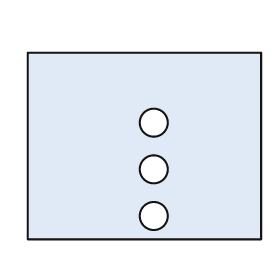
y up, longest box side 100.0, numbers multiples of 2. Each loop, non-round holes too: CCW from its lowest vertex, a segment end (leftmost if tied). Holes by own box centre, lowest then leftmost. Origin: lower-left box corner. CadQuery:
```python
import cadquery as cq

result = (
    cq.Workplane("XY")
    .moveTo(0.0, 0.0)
    .lineTo(100.0, 0.0)
    .lineTo(100.0, 80.0)
    .lineTo(0.0, 80.0)
    .close()
    .moveTo(54.0, 10.0)
    .circle(6.0)
    .moveTo(54.0, 30.0)
    .circle(6.0)
    .moveTo(54.0, 50.0)
    .circle(6.0)
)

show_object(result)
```